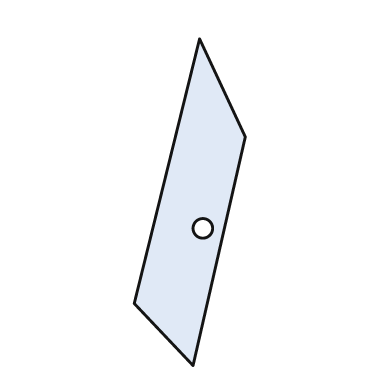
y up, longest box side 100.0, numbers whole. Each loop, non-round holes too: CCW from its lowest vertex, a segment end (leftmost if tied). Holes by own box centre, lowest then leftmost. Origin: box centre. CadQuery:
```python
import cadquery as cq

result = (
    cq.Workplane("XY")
    .moveTo(1.0, -50.0)
    .lineTo(17.0, 20.0)
    .lineTo(3.0, 50.0)
    .lineTo(-17.0, -31.0)
    .close()
    .moveTo(4.0, -8.0)
    .circle(3.0)
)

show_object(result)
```